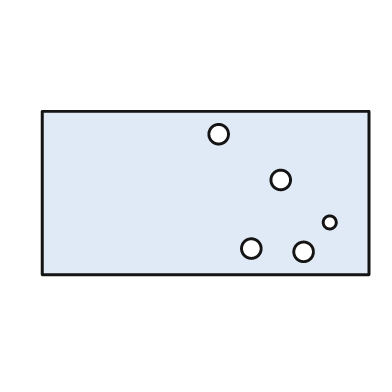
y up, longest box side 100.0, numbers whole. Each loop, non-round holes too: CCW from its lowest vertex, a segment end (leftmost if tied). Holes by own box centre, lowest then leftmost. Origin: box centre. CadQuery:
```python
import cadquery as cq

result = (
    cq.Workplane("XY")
    .moveTo(-50.0, -25.0)
    .lineTo(50.0, -25.0)
    .lineTo(50.0, 25.0)
    .lineTo(-50.0, 25.0)
    .close()
    .moveTo(30.0, -18.0)
    .circle(3.0)
    .moveTo(14.0, -17.0)
    .circle(3.0)
    .moveTo(38.0, -9.0)
    .circle(2.0)
    .moveTo(23.0, 4.0)
    .circle(3.0)
    .moveTo(4.0, 18.0)
    .circle(3.0)
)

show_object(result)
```